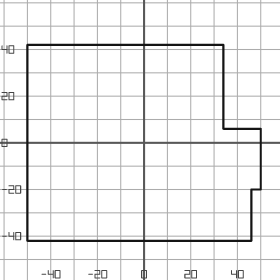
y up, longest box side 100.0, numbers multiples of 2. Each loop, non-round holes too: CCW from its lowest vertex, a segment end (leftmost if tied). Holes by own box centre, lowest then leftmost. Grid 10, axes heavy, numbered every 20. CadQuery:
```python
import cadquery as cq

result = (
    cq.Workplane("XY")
    .moveTo(-50.0, -42.0)
    .lineTo(46.0, -42.0)
    .lineTo(46.0, -20.0)
    .lineTo(50.0, -20.0)
    .lineTo(50.0, 6.0)
    .lineTo(34.0, 6.0)
    .lineTo(34.0, 42.0)
    .lineTo(-50.0, 42.0)
    .close()
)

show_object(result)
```